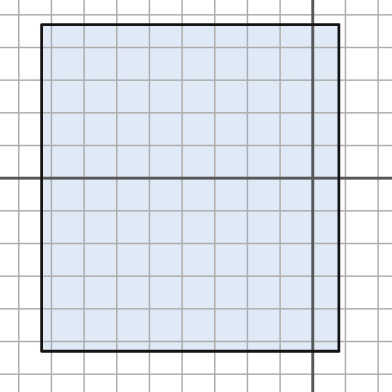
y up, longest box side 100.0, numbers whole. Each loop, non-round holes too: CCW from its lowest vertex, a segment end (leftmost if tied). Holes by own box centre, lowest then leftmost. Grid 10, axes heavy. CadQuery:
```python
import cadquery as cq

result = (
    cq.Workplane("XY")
    .moveTo(-83.0, -53.0)
    .lineTo(8.0, -53.0)
    .lineTo(8.0, 47.0)
    .lineTo(-83.0, 47.0)
    .close()
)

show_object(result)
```